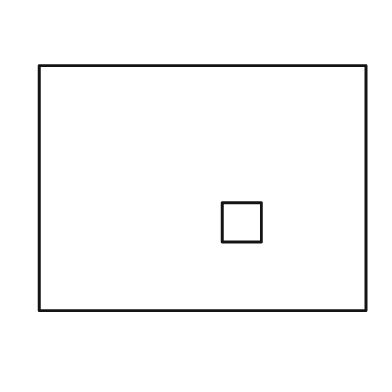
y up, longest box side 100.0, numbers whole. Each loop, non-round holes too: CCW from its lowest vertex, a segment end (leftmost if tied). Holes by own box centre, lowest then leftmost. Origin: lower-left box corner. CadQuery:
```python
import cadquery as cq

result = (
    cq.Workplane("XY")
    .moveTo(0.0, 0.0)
    .lineTo(100.0, 0.0)
    .lineTo(100.0, 75.0)
    .lineTo(0.0, 75.0)
    .close()
    .moveTo(56.0, 21.0)
    .lineTo(68.0, 21.0)
    .lineTo(68.0, 33.0)
    .lineTo(56.0, 33.0)
    .close()
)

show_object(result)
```